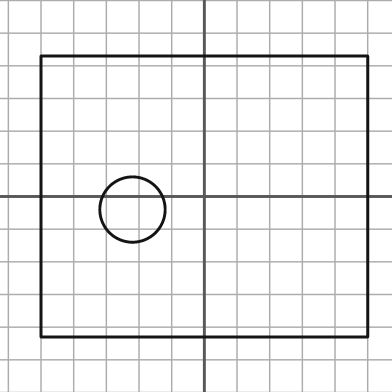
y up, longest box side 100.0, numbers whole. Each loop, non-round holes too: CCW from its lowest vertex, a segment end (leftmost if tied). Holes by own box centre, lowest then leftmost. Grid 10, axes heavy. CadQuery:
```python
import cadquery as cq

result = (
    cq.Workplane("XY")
    .moveTo(-50.0, -43.0)
    .lineTo(50.0, -43.0)
    .lineTo(50.0, 43.0)
    .lineTo(-50.0, 43.0)
    .close()
    .moveTo(-22.0, -4.0)
    .circle(10.0)
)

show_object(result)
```